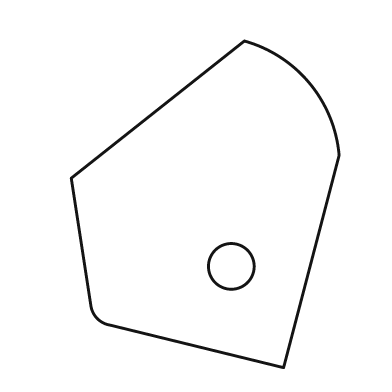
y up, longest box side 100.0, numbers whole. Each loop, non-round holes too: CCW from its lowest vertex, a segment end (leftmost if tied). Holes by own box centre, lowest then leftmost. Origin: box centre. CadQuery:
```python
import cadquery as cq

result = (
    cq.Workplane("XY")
    .moveTo(24.0, -50.0)
    .lineTo(41.0, 15.0)
    .threePointArc((32.0, 37.0), (12.0, 50.0))
    .lineTo(-41.0, 8.0)
    .lineTo(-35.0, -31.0)
    .threePointArc((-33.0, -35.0), (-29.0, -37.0))
    .close()
    .moveTo(8.0, -19.0)
    .circle(7.0)
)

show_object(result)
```